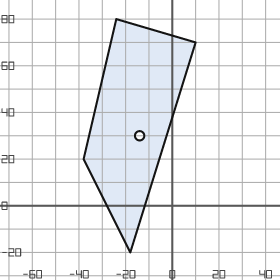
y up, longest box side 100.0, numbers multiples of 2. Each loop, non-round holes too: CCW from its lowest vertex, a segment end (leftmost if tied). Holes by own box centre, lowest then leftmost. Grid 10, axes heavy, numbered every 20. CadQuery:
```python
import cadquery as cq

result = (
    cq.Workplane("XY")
    .moveTo(-18.0, -20.0)
    .lineTo(10.0, 70.0)
    .lineTo(-24.0, 80.0)
    .lineTo(-38.0, 20.0)
    .close()
    .moveTo(-14.0, 30.0)
    .circle(2.0)
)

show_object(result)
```